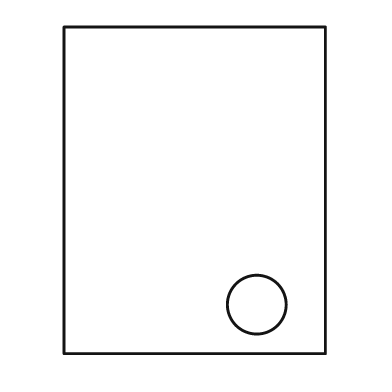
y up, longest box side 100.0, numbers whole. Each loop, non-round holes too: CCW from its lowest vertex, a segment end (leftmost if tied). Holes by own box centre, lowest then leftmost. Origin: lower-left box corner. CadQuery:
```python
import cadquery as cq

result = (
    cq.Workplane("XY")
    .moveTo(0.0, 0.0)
    .lineTo(80.0, 0.0)
    .lineTo(80.0, 100.0)
    .lineTo(0.0, 100.0)
    .close()
    .moveTo(59.0, 15.0)
    .circle(9.0)
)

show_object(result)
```